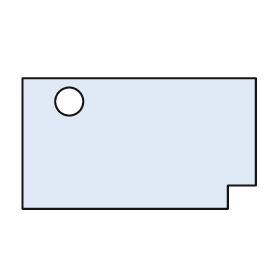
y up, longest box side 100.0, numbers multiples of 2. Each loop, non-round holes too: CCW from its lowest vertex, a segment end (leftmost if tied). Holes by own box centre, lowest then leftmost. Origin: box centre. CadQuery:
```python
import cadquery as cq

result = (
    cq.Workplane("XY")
    .moveTo(-50.0, -28.0)
    .lineTo(38.0, -28.0)
    .lineTo(38.0, -18.0)
    .lineTo(50.0, -18.0)
    .lineTo(50.0, 28.0)
    .lineTo(-50.0, 28.0)
    .close()
    .moveTo(-30.0, 18.0)
    .circle(6.0)
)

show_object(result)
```